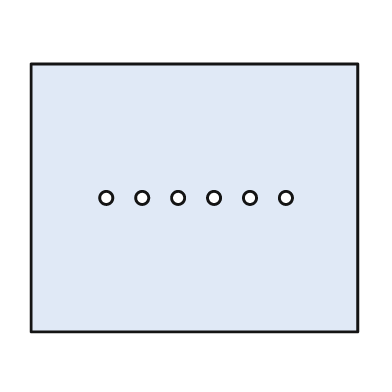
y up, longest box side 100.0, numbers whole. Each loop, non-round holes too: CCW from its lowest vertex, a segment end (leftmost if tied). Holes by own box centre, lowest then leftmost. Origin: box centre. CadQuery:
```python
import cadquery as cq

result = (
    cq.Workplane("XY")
    .moveTo(-50.0, -41.0)
    .lineTo(50.0, -41.0)
    .lineTo(50.0, 41.0)
    .lineTo(-50.0, 41.0)
    .close()
    .moveTo(-27.0, 0.0)
    .circle(2.0)
    .moveTo(-16.0, 0.0)
    .circle(2.0)
    .moveTo(-5.0, 0.0)
    .circle(2.0)
    .moveTo(6.0, 0.0)
    .circle(2.0)
    .moveTo(17.0, 0.0)
    .circle(2.0)
    .moveTo(28.0, 0.0)
    .circle(2.0)
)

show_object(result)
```